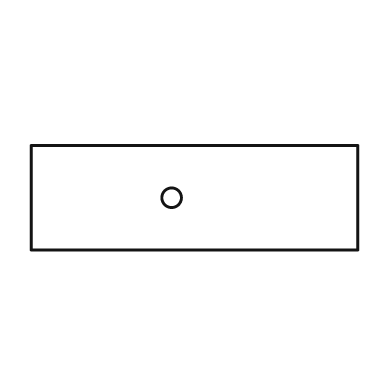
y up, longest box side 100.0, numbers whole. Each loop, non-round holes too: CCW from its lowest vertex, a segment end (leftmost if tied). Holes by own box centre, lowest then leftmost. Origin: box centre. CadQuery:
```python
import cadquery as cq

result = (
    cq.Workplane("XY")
    .moveTo(-50.0, -16.0)
    .lineTo(50.0, -16.0)
    .lineTo(50.0, 16.0)
    .lineTo(-50.0, 16.0)
    .close()
    .moveTo(-7.0, 0.0)
    .circle(3.0)
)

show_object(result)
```